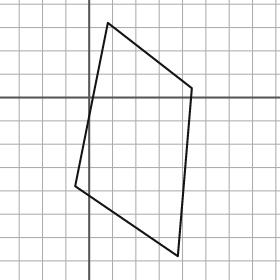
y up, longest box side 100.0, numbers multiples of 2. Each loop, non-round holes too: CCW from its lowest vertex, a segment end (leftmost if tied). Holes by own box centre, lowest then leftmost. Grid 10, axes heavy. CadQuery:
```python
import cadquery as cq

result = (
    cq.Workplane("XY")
    .moveTo(38.0, -68.0)
    .lineTo(44.0, 4.0)
    .lineTo(8.0, 32.0)
    .lineTo(-6.0, -38.0)
    .close()
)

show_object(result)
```